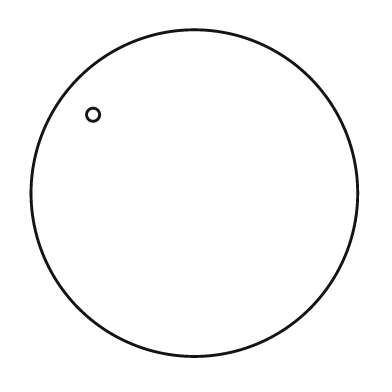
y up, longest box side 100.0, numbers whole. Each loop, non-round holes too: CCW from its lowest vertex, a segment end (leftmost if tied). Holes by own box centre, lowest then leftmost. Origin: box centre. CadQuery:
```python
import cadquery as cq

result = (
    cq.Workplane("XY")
    .moveTo(0.0, 0.0)
    .circle(50.0)
    .moveTo(-31.0, 24.0)
    .circle(2.0)
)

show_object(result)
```